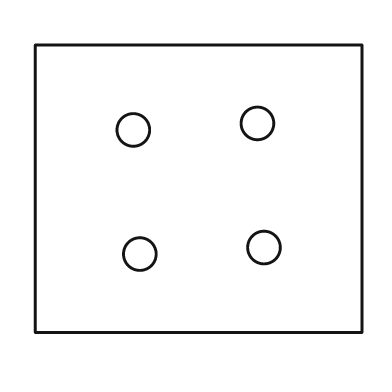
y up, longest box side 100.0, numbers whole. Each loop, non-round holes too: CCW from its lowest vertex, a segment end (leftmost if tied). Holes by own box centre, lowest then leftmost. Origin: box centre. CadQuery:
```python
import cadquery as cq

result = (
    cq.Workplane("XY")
    .moveTo(-50.0, -44.0)
    .lineTo(50.0, -44.0)
    .lineTo(50.0, 44.0)
    .lineTo(-50.0, 44.0)
    .close()
    .moveTo(-18.0, -20.0)
    .circle(5.0)
    .moveTo(20.0, -18.0)
    .circle(5.0)
    .moveTo(-20.0, 18.0)
    .circle(5.0)
    .moveTo(18.0, 20.0)
    .circle(5.0)
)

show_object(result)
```